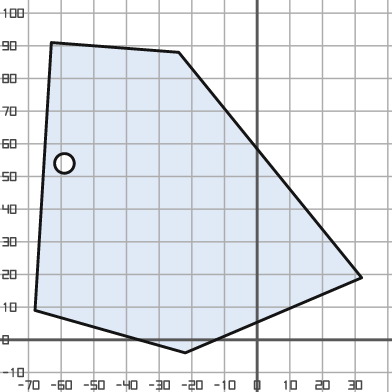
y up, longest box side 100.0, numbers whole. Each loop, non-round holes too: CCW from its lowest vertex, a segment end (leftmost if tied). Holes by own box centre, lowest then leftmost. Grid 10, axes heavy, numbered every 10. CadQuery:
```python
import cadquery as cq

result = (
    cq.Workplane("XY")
    .moveTo(-22.0, -4.0)
    .lineTo(32.0, 19.0)
    .lineTo(-24.0, 88.0)
    .lineTo(-63.0, 91.0)
    .lineTo(-68.0, 9.0)
    .close()
    .moveTo(-59.0, 54.0)
    .circle(3.0)
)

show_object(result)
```